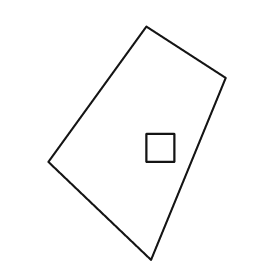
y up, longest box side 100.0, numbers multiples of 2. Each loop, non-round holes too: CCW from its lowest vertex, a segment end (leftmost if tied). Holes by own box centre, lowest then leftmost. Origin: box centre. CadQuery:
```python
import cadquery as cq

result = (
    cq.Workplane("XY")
    .moveTo(6.0, -50.0)
    .lineTo(38.0, 28.0)
    .lineTo(4.0, 50.0)
    .lineTo(-38.0, -8.0)
    .close()
    .moveTo(4.0, -8.0)
    .lineTo(16.0, -8.0)
    .lineTo(16.0, 4.0)
    .lineTo(4.0, 4.0)
    .close()
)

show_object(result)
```